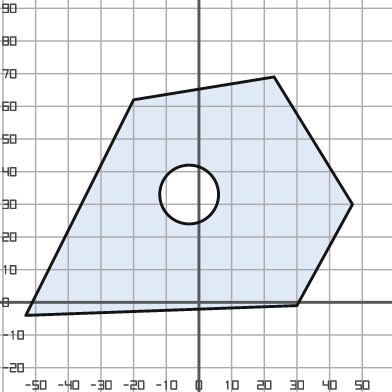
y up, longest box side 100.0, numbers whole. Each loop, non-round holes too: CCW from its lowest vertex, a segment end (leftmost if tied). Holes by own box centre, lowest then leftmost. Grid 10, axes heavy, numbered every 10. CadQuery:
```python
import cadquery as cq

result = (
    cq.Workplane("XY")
    .moveTo(-53.0, -4.0)
    .lineTo(30.0, -1.0)
    .lineTo(47.0, 30.0)
    .lineTo(23.0, 69.0)
    .lineTo(-20.0, 62.0)
    .close()
    .moveTo(-3.0, 33.0)
    .circle(9.0)
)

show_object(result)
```